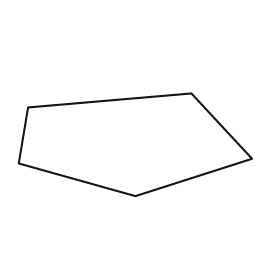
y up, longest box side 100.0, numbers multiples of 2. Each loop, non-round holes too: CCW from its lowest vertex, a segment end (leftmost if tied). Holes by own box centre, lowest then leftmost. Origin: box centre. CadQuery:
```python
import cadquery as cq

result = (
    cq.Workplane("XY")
    .moveTo(0.0, -22.0)
    .lineTo(50.0, -6.0)
    .lineTo(24.0, 22.0)
    .lineTo(-46.0, 16.0)
    .lineTo(-50.0, -8.0)
    .close()
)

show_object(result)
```